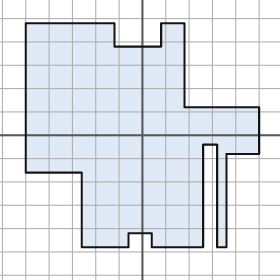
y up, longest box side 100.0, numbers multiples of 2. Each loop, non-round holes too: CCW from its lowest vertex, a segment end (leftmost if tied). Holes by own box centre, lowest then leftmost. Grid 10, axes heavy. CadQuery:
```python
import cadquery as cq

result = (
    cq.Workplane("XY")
    .moveTo(-26.0, -48.0)
    .lineTo(-6.0, -48.0)
    .lineTo(-6.0, -42.0)
    .lineTo(4.0, -42.0)
    .lineTo(4.0, -48.0)
    .lineTo(26.0, -48.0)
    .lineTo(26.0, -4.0)
    .lineTo(32.0, -4.0)
    .lineTo(32.0, -48.0)
    .lineTo(36.0, -48.0)
    .lineTo(36.0, -8.0)
    .lineTo(50.0, -8.0)
    .lineTo(50.0, 12.0)
    .lineTo(18.0, 12.0)
    .lineTo(18.0, 48.0)
    .lineTo(8.0, 48.0)
    .lineTo(8.0, 38.0)
    .lineTo(-12.0, 38.0)
    .lineTo(-12.0, 48.0)
    .lineTo(-50.0, 48.0)
    .lineTo(-50.0, -16.0)
    .lineTo(-26.0, -16.0)
    .close()
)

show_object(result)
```